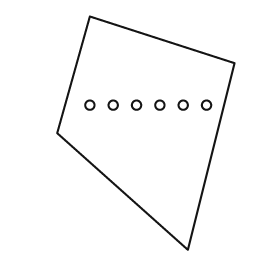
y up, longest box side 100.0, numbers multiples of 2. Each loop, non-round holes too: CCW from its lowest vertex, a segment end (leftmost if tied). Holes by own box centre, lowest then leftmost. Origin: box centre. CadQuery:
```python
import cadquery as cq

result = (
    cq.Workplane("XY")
    .moveTo(18.0, -50.0)
    .lineTo(38.0, 30.0)
    .lineTo(-24.0, 50.0)
    .lineTo(-38.0, 0.0)
    .close()
    .moveTo(-24.0, 12.0)
    .circle(2.0)
    .moveTo(-14.0, 12.0)
    .circle(2.0)
    .moveTo(-4.0, 12.0)
    .circle(2.0)
    .moveTo(6.0, 12.0)
    .circle(2.0)
    .moveTo(16.0, 12.0)
    .circle(2.0)
    .moveTo(26.0, 12.0)
    .circle(2.0)
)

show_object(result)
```